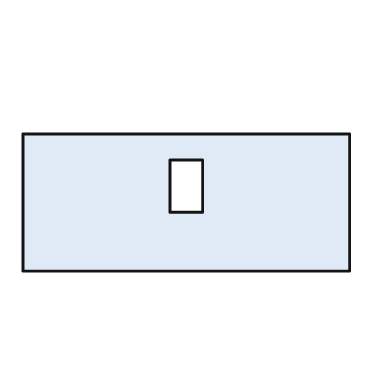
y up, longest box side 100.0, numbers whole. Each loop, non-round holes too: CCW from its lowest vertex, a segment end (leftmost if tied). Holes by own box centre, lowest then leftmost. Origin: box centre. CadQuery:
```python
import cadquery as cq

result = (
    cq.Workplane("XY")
    .moveTo(-50.0, -21.0)
    .lineTo(50.0, -21.0)
    .lineTo(50.0, 21.0)
    .lineTo(-50.0, 21.0)
    .close()
    .moveTo(-5.0, -3.0)
    .lineTo(5.0, -3.0)
    .lineTo(5.0, 13.0)
    .lineTo(-5.0, 13.0)
    .close()
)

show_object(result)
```